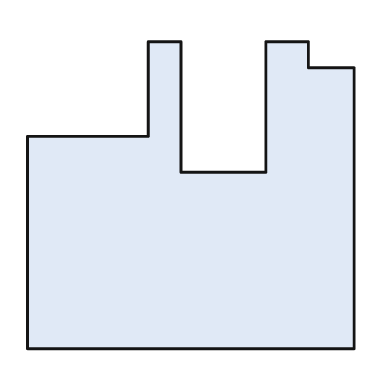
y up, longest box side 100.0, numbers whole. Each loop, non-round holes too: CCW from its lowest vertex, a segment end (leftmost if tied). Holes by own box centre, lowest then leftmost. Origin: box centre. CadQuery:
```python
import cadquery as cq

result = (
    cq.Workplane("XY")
    .moveTo(-50.0, -47.0)
    .lineTo(50.0, -47.0)
    .lineTo(50.0, 39.0)
    .lineTo(36.0, 39.0)
    .lineTo(36.0, 47.0)
    .lineTo(23.0, 47.0)
    .lineTo(23.0, 7.0)
    .lineTo(-3.0, 7.0)
    .lineTo(-3.0, 47.0)
    .lineTo(-13.0, 47.0)
    .lineTo(-13.0, 18.0)
    .lineTo(-50.0, 18.0)
    .close()
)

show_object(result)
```